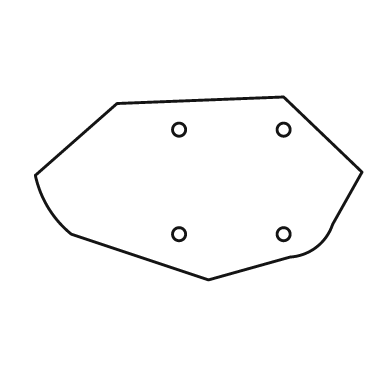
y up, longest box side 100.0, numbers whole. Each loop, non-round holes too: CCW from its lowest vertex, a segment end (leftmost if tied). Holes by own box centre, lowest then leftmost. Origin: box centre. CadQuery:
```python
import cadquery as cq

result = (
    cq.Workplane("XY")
    .moveTo(3.0, -28.0)
    .lineTo(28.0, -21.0)
    .threePointArc((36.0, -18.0), (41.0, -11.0))
    .lineTo(50.0, 5.0)
    .lineTo(26.0, 28.0)
    .lineTo(-25.0, 26.0)
    .lineTo(-50.0, 4.0)
    .threePointArc((-46.0, -6.0), (-39.0, -14.0))
    .close()
    .moveTo(-6.0, -14.0)
    .circle(2.0)
    .moveTo(26.0, -14.0)
    .circle(2.0)
    .moveTo(-6.0, 18.0)
    .circle(2.0)
    .moveTo(26.0, 18.0)
    .circle(2.0)
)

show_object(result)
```